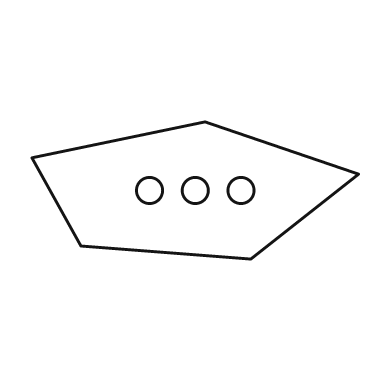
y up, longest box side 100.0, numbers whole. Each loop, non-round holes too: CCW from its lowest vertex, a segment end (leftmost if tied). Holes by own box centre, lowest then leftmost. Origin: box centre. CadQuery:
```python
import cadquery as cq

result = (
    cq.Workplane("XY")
    .moveTo(17.0, -21.0)
    .lineTo(50.0, 5.0)
    .lineTo(3.0, 21.0)
    .lineTo(-50.0, 10.0)
    .lineTo(-35.0, -17.0)
    .close()
    .moveTo(-14.0, 0.0)
    .circle(4.0)
    .moveTo(0.0, 0.0)
    .circle(4.0)
    .moveTo(14.0, 0.0)
    .circle(4.0)
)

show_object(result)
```